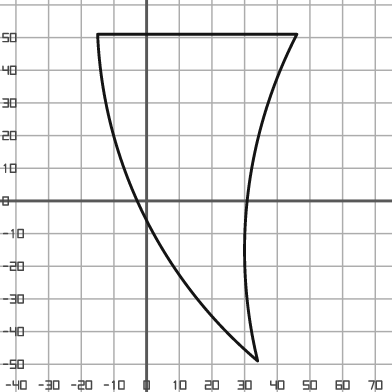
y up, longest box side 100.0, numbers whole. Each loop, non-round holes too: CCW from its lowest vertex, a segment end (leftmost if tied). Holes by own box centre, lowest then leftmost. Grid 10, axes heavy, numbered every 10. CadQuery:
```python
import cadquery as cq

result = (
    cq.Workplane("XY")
    .moveTo(34.0, -49.0)
    .threePointArc((31.0, 2.0), (46.0, 51.0))
    .lineTo(-15.0, 51.0)
    .threePointArc((-1.0, -4.0), (34.0, -49.0))
    .close()
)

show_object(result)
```